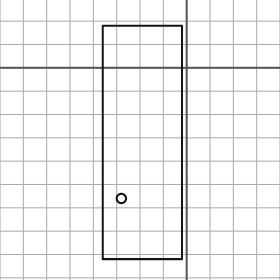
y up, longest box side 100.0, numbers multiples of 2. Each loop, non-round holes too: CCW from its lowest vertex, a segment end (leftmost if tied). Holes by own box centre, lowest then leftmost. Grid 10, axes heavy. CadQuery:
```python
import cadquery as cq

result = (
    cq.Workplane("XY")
    .moveTo(-36.0, -82.0)
    .lineTo(-2.0, -82.0)
    .lineTo(-2.0, 18.0)
    .lineTo(-36.0, 18.0)
    .close()
    .moveTo(-28.0, -56.0)
    .circle(2.0)
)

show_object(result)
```